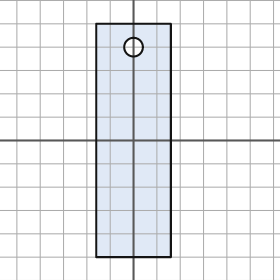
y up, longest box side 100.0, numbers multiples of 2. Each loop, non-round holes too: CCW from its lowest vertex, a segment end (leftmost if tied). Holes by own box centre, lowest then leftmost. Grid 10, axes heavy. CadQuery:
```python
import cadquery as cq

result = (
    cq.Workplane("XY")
    .moveTo(-16.0, -50.0)
    .lineTo(16.0, -50.0)
    .lineTo(16.0, 50.0)
    .lineTo(-16.0, 50.0)
    .close()
    .moveTo(0.0, 40.0)
    .circle(4.0)
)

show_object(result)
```